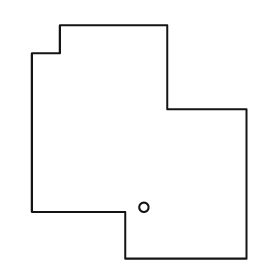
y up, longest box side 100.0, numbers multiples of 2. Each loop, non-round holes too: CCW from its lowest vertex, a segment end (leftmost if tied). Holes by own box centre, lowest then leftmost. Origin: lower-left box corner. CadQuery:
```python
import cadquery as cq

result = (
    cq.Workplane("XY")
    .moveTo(40.0, 0.0)
    .lineTo(92.0, 0.0)
    .lineTo(92.0, 64.0)
    .lineTo(58.0, 64.0)
    .lineTo(58.0, 100.0)
    .lineTo(12.0, 100.0)
    .lineTo(12.0, 88.0)
    .lineTo(0.0, 88.0)
    .lineTo(0.0, 20.0)
    .lineTo(40.0, 20.0)
    .close()
    .moveTo(48.0, 22.0)
    .circle(2.0)
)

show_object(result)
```